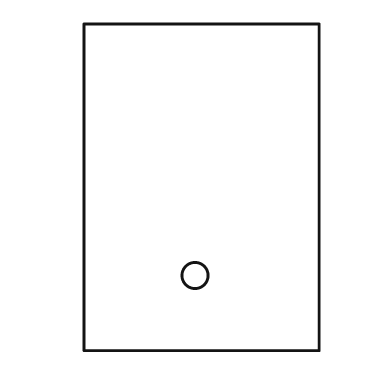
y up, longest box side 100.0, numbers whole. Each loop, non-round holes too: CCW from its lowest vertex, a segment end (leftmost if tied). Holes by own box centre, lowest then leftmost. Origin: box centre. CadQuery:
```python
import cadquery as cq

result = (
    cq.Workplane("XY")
    .moveTo(-36.0, -50.0)
    .lineTo(36.0, -50.0)
    .lineTo(36.0, 50.0)
    .lineTo(-36.0, 50.0)
    .close()
    .moveTo(-2.0, -27.0)
    .circle(4.0)
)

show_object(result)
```